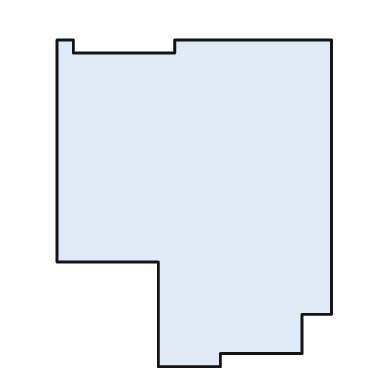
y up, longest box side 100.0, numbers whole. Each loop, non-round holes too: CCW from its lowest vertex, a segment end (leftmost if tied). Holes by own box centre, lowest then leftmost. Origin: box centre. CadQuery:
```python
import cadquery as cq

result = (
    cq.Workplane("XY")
    .moveTo(-11.0, -50.0)
    .lineTo(8.0, -50.0)
    .lineTo(8.0, -46.0)
    .lineTo(33.0, -46.0)
    .lineTo(33.0, -34.0)
    .lineTo(42.0, -34.0)
    .lineTo(42.0, 50.0)
    .lineTo(-6.0, 50.0)
    .lineTo(-6.0, 46.0)
    .lineTo(-37.0, 46.0)
    .lineTo(-37.0, 50.0)
    .lineTo(-42.0, 50.0)
    .lineTo(-42.0, -18.0)
    .lineTo(-11.0, -18.0)
    .close()
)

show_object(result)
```